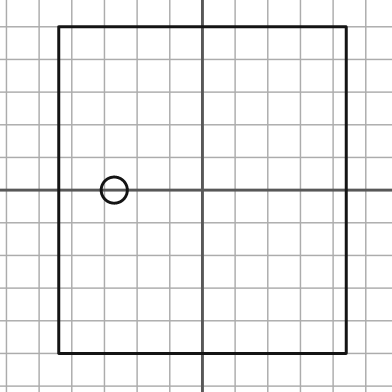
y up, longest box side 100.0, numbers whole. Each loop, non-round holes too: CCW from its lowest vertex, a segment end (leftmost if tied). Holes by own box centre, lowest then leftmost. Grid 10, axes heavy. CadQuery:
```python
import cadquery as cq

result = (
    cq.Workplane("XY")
    .moveTo(-44.0, -50.0)
    .lineTo(44.0, -50.0)
    .lineTo(44.0, 50.0)
    .lineTo(-44.0, 50.0)
    .close()
    .moveTo(-27.0, 0.0)
    .circle(4.0)
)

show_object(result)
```